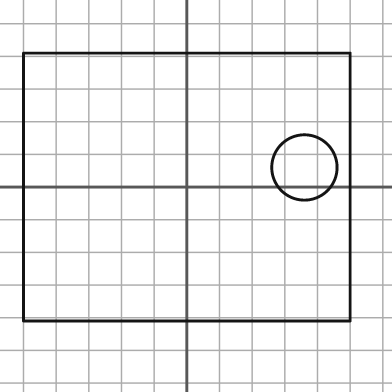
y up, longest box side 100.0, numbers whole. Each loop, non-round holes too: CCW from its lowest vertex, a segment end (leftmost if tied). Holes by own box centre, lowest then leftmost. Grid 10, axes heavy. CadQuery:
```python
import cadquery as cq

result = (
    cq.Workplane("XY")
    .moveTo(-50.0, -41.0)
    .lineTo(50.0, -41.0)
    .lineTo(50.0, 41.0)
    .lineTo(-50.0, 41.0)
    .close()
    .moveTo(36.0, 6.0)
    .circle(10.0)
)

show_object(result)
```